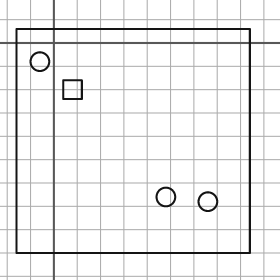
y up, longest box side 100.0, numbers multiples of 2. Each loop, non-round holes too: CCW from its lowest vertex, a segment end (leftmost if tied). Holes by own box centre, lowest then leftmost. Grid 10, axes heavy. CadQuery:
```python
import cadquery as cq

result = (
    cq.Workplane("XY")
    .moveTo(-16.0, -90.0)
    .lineTo(84.0, -90.0)
    .lineTo(84.0, 6.0)
    .lineTo(-16.0, 6.0)
    .close()
    .moveTo(66.0, -68.0)
    .circle(4.0)
    .moveTo(48.0, -66.0)
    .circle(4.0)
    .moveTo(4.0, -24.0)
    .lineTo(12.0, -24.0)
    .lineTo(12.0, -16.0)
    .lineTo(4.0, -16.0)
    .close()
    .moveTo(-6.0, -8.0)
    .circle(4.0)
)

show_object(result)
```